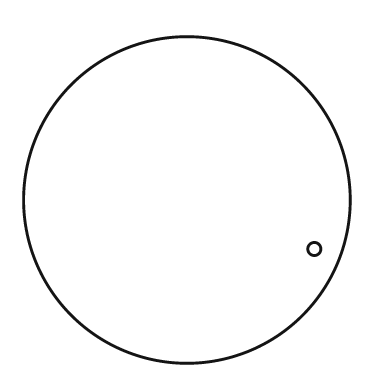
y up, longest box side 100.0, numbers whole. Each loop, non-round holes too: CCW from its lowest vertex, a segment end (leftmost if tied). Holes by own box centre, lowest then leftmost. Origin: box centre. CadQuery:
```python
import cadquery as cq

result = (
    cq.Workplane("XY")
    .moveTo(0.0, 0.0)
    .circle(50.0)
    .moveTo(39.0, -15.0)
    .circle(2.0)
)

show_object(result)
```